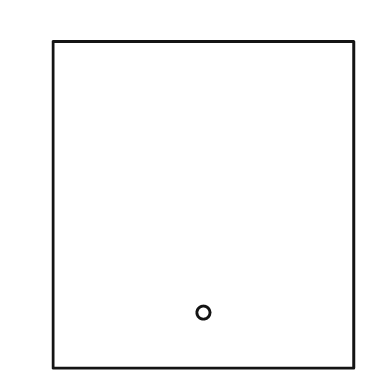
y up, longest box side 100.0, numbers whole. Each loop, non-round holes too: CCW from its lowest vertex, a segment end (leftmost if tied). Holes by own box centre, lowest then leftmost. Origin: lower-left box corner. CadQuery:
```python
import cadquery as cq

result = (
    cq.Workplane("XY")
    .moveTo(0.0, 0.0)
    .lineTo(92.0, 0.0)
    .lineTo(92.0, 100.0)
    .lineTo(0.0, 100.0)
    .close()
    .moveTo(46.0, 17.0)
    .circle(2.0)
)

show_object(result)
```